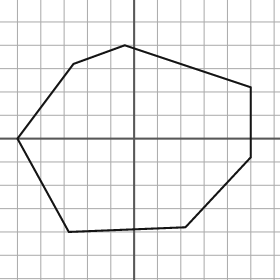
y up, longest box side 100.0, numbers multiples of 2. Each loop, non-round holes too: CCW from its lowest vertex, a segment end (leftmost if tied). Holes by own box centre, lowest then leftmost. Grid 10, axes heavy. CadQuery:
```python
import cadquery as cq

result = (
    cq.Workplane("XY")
    .moveTo(-28.0, -40.0)
    .lineTo(22.0, -38.0)
    .lineTo(50.0, -8.0)
    .lineTo(50.0, 22.0)
    .lineTo(-4.0, 40.0)
    .lineTo(-26.0, 32.0)
    .lineTo(-50.0, 0.0)
    .close()
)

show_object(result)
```